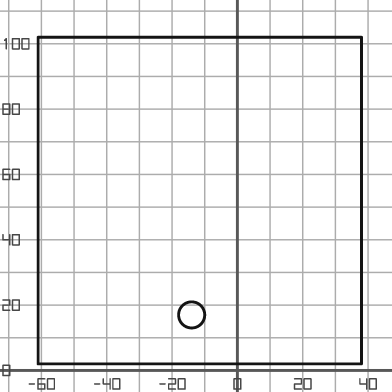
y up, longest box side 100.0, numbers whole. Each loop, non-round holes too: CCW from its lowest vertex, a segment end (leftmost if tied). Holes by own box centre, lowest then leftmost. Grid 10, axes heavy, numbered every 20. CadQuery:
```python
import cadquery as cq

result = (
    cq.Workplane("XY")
    .moveTo(-61.0, 2.0)
    .lineTo(38.0, 2.0)
    .lineTo(38.0, 102.0)
    .lineTo(-61.0, 102.0)
    .close()
    .moveTo(-14.0, 17.0)
    .circle(4.0)
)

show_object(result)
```